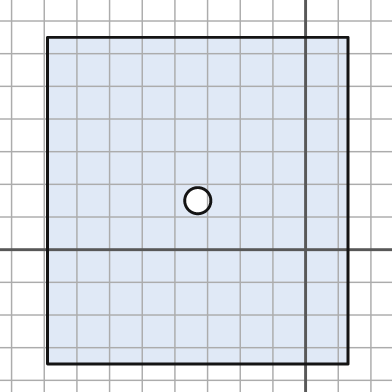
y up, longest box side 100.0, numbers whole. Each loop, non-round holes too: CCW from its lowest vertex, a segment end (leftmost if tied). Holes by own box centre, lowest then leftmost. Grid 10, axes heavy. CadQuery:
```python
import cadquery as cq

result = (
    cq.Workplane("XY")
    .moveTo(-79.0, -35.0)
    .lineTo(13.0, -35.0)
    .lineTo(13.0, 65.0)
    .lineTo(-79.0, 65.0)
    .close()
    .moveTo(-33.0, 15.0)
    .circle(4.0)
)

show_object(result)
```